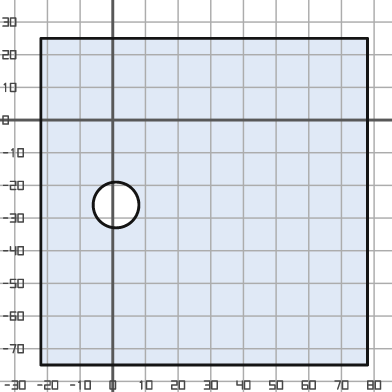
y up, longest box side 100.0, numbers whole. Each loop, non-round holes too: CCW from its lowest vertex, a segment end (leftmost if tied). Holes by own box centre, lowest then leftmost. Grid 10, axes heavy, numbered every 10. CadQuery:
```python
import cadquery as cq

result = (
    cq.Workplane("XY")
    .moveTo(-22.0, -75.0)
    .lineTo(78.0, -75.0)
    .lineTo(78.0, 25.0)
    .lineTo(-22.0, 25.0)
    .close()
    .moveTo(1.0, -26.0)
    .circle(7.0)
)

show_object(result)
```